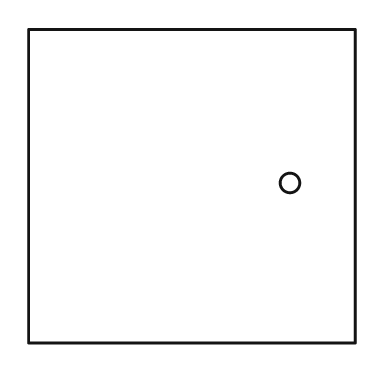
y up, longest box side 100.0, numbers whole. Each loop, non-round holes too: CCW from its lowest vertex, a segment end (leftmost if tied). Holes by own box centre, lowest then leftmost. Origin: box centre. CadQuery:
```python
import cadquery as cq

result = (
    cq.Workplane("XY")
    .moveTo(-50.0, -48.0)
    .lineTo(50.0, -48.0)
    .lineTo(50.0, 48.0)
    .lineTo(-50.0, 48.0)
    .close()
    .moveTo(30.0, 1.0)
    .circle(3.0)
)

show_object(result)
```